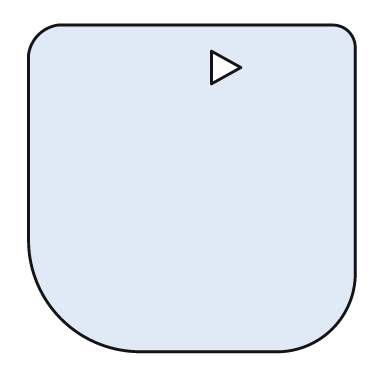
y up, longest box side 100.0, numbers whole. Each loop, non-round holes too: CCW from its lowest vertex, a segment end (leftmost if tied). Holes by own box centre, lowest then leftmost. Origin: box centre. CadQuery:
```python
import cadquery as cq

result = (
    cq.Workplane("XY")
    .moveTo(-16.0, -50.0)
    .lineTo(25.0, -50.0)
    .threePointArc((43.0, -43.0), (50.0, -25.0))
    .lineTo(50.0, 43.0)
    .threePointArc((48.0, 48.0), (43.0, 50.0))
    .lineTo(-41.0, 50.0)
    .threePointArc((-47.0, 47.0), (-50.0, 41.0))
    .lineTo(-50.0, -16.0)
    .threePointArc((-40.0, -40.0), (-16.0, -50.0))
    .close()
    .moveTo(6.0, 32.0)
    .lineTo(15.0, 37.0)
    .lineTo(6.0, 42.0)
    .close()
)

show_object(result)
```